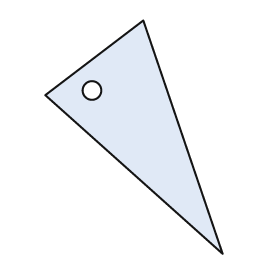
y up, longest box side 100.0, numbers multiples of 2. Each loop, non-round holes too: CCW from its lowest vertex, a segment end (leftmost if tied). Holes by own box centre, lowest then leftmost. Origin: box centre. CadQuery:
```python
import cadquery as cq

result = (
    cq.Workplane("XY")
    .moveTo(38.0, -50.0)
    .lineTo(4.0, 50.0)
    .lineTo(-38.0, 18.0)
    .close()
    .moveTo(-18.0, 20.0)
    .circle(4.0)
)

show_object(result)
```